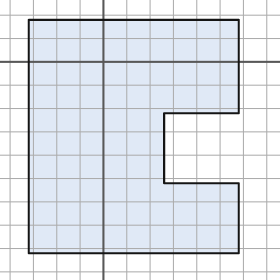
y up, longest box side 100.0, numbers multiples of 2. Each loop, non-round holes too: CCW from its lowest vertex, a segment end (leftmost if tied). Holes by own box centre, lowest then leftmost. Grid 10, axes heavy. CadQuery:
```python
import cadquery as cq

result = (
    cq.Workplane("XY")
    .moveTo(-32.0, -82.0)
    .lineTo(58.0, -82.0)
    .lineTo(58.0, -52.0)
    .lineTo(26.0, -52.0)
    .lineTo(26.0, -22.0)
    .lineTo(58.0, -22.0)
    .lineTo(58.0, 18.0)
    .lineTo(-32.0, 18.0)
    .close()
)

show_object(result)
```